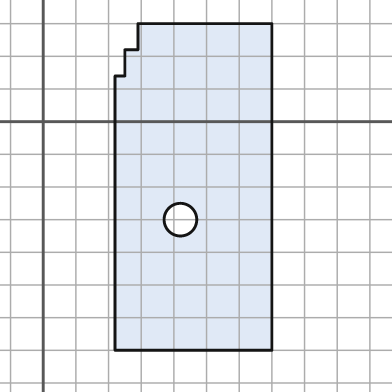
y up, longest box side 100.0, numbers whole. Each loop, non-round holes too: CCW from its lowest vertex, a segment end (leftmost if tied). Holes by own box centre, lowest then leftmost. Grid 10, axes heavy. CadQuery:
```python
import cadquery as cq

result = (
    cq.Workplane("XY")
    .moveTo(22.0, -70.0)
    .lineTo(70.0, -70.0)
    .lineTo(70.0, 30.0)
    .lineTo(29.0, 30.0)
    .lineTo(29.0, 22.0)
    .lineTo(25.0, 22.0)
    .lineTo(25.0, 14.0)
    .lineTo(22.0, 14.0)
    .close()
    .moveTo(42.0, -30.0)
    .circle(5.0)
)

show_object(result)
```